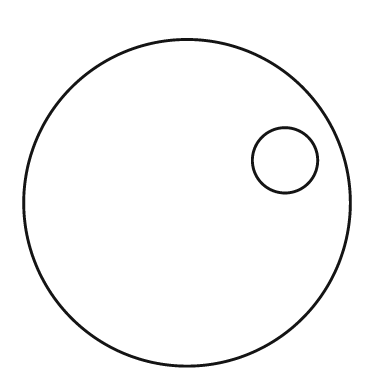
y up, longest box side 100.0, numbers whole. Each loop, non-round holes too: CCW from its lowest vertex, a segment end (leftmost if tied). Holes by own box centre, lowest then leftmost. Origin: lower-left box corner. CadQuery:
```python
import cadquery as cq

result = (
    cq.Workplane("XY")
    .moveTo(50.0, 50.0)
    .circle(50.0)
    .moveTo(80.0, 63.0)
    .circle(10.0)
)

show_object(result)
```